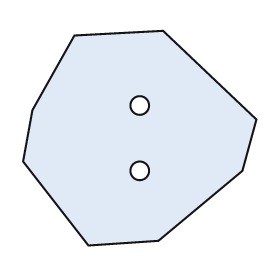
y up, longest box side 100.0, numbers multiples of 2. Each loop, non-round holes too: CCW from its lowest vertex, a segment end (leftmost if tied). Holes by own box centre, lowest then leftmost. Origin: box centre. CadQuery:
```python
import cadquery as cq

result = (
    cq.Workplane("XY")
    .moveTo(-22.0, -46.0)
    .lineTo(8.0, -44.0)
    .lineTo(44.0, -14.0)
    .lineTo(50.0, 8.0)
    .lineTo(10.0, 46.0)
    .lineTo(-28.0, 44.0)
    .lineTo(-46.0, 12.0)
    .lineTo(-50.0, -10.0)
    .close()
    .moveTo(0.0, -14.0)
    .circle(4.0)
    .moveTo(0.0, 14.0)
    .circle(4.0)
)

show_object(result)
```